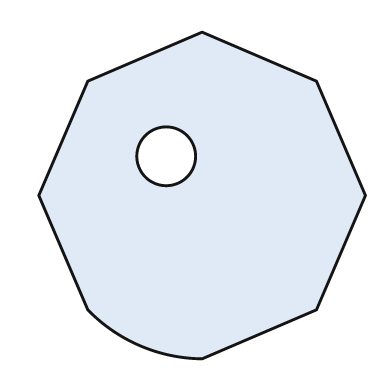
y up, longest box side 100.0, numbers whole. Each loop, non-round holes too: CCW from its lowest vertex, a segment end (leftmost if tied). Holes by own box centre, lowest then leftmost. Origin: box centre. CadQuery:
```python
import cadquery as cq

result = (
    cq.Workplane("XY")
    .moveTo(0.0, -50.0)
    .lineTo(35.0, -35.0)
    .lineTo(50.0, 0.0)
    .lineTo(35.0, 35.0)
    .lineTo(0.0, 50.0)
    .lineTo(-35.0, 35.0)
    .lineTo(-50.0, 0.0)
    .lineTo(-35.0, -35.0)
    .threePointArc((-19.0, -46.0), (0.0, -50.0))
    .close()
    .moveTo(-11.0, 12.0)
    .circle(9.0)
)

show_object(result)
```